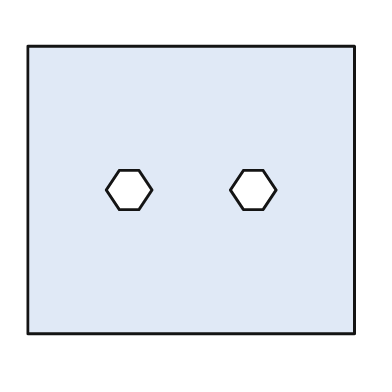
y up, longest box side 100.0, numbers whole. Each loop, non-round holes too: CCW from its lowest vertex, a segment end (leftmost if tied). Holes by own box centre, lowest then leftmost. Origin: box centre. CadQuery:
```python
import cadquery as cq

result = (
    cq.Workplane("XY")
    .moveTo(-50.0, -44.0)
    .lineTo(50.0, -44.0)
    .lineTo(50.0, 44.0)
    .lineTo(-50.0, 44.0)
    .close()
    .moveTo(-22.0, -6.0)
    .lineTo(-16.0, -6.0)
    .lineTo(-12.0, 0.0)
    .lineTo(-16.0, 6.0)
    .lineTo(-22.0, 6.0)
    .lineTo(-26.0, 0.0)
    .close()
    .moveTo(16.0, -6.0)
    .lineTo(22.0, -6.0)
    .lineTo(26.0, 0.0)
    .lineTo(22.0, 6.0)
    .lineTo(16.0, 6.0)
    .lineTo(12.0, 0.0)
    .close()
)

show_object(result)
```